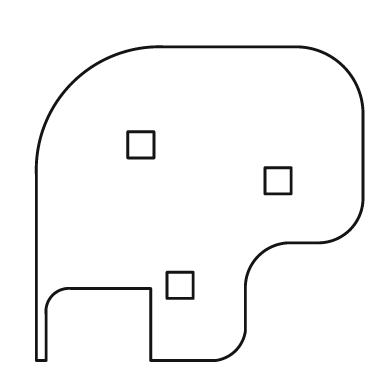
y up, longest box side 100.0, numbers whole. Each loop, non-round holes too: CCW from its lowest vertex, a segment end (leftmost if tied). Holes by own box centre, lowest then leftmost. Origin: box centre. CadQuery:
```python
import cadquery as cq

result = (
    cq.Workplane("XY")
    .moveTo(-50.0, -48.0)
    .lineTo(-47.0, -48.0)
    .lineTo(-47.0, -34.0)
    .threePointArc((-45.0, -28.0), (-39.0, -26.0))
    .lineTo(-15.0, -26.0)
    .lineTo(-15.0, -48.0)
    .lineTo(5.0, -48.0)
    .threePointArc((11.0, -45.0), (14.0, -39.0))
    .lineTo(14.0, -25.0)
    .threePointArc((18.0, -16.0), (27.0, -12.0))
    .lineTo(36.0, -12.0)
    .threePointArc((46.0, -8.0), (50.0, 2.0))
    .lineTo(50.0, 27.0)
    .threePointArc((44.0, 42.0), (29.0, 48.0))
    .lineTo(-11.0, 48.0)
    .threePointArc((-39.0, 37.0), (-50.0, 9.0))
    .close()
    .moveTo(-10.0, -29.0)
    .lineTo(-2.0, -29.0)
    .lineTo(-2.0, -21.0)
    .lineTo(-10.0, -21.0)
    .close()
    .moveTo(20.0, 3.0)
    .lineTo(28.0, 3.0)
    .lineTo(28.0, 11.0)
    .lineTo(20.0, 11.0)
    .close()
    .moveTo(-22.0, 14.0)
    .lineTo(-14.0, 14.0)
    .lineTo(-14.0, 22.0)
    .lineTo(-22.0, 22.0)
    .close()
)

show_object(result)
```